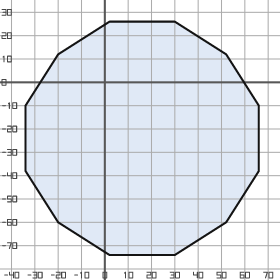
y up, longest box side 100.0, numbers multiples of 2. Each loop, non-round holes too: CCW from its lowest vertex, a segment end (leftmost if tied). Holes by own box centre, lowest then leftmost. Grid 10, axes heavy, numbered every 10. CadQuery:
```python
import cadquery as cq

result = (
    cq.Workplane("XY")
    .moveTo(2.0, -74.0)
    .lineTo(30.0, -74.0)
    .lineTo(52.0, -60.0)
    .lineTo(66.0, -38.0)
    .lineTo(66.0, -10.0)
    .lineTo(52.0, 12.0)
    .lineTo(30.0, 26.0)
    .lineTo(2.0, 26.0)
    .lineTo(-20.0, 12.0)
    .lineTo(-34.0, -10.0)
    .lineTo(-34.0, -38.0)
    .lineTo(-20.0, -60.0)
    .close()
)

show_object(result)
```